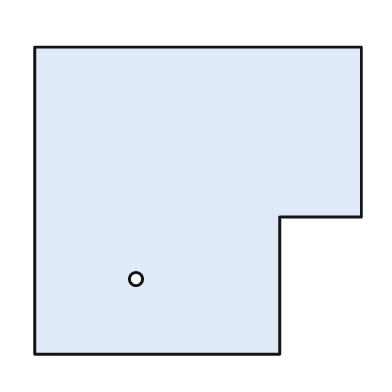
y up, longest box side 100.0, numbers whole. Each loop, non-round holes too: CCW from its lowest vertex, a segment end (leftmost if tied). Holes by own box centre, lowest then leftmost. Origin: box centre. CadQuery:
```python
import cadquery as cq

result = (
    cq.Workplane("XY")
    .moveTo(-50.0, -47.0)
    .lineTo(25.0, -47.0)
    .lineTo(25.0, -5.0)
    .lineTo(50.0, -5.0)
    .lineTo(50.0, 47.0)
    .lineTo(-50.0, 47.0)
    .close()
    .moveTo(-19.0, -24.0)
    .circle(2.0)
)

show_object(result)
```